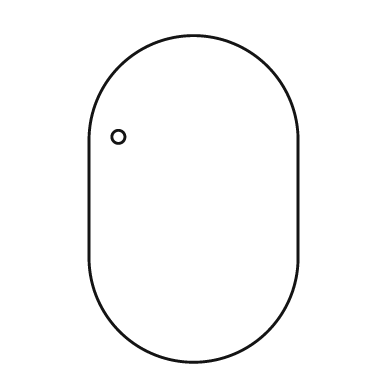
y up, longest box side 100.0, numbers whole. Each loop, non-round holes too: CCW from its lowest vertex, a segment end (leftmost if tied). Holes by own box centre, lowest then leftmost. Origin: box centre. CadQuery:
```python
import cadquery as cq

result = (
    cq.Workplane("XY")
    .moveTo(-32.0, -18.0)
    .threePointArc((0.0, -50.0), (32.0, -18.0))
    .lineTo(32.0, 18.0)
    .threePointArc((0.0, 50.0), (-32.0, 18.0))
    .close()
    .moveTo(-23.0, 19.0)
    .circle(2.0)
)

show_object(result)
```